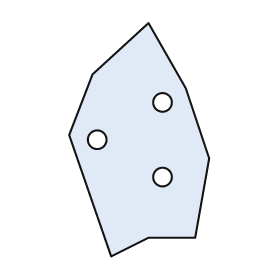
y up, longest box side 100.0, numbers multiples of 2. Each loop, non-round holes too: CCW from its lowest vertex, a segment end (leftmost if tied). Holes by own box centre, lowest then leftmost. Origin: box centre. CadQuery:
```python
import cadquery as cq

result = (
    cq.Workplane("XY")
    .moveTo(-12.0, -50.0)
    .lineTo(4.0, -42.0)
    .lineTo(24.0, -42.0)
    .lineTo(30.0, -8.0)
    .lineTo(20.0, 22.0)
    .lineTo(4.0, 50.0)
    .lineTo(-20.0, 28.0)
    .lineTo(-30.0, 2.0)
    .close()
    .moveTo(10.0, -16.0)
    .circle(4.0)
    .moveTo(-18.0, 0.0)
    .circle(4.0)
    .moveTo(10.0, 16.0)
    .circle(4.0)
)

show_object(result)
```